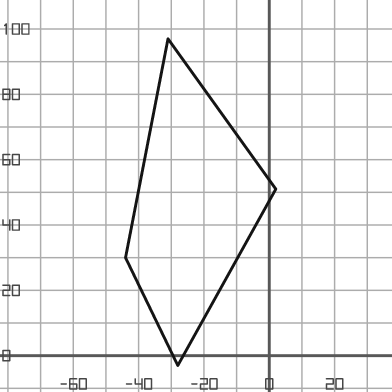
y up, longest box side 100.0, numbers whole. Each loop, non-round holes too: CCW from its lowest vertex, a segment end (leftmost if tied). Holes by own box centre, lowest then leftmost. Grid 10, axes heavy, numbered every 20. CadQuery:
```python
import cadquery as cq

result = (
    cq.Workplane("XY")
    .moveTo(-28.0, -3.0)
    .lineTo(2.0, 51.0)
    .lineTo(-31.0, 97.0)
    .lineTo(-44.0, 30.0)
    .close()
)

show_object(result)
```